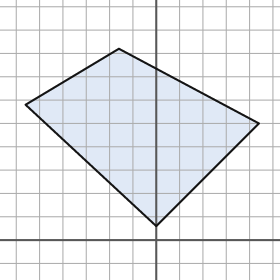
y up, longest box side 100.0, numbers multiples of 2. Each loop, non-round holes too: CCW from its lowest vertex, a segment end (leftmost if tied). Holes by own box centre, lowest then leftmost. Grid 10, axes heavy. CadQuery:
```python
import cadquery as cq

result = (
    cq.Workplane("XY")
    .moveTo(0.0, 6.0)
    .lineTo(44.0, 50.0)
    .lineTo(-16.0, 82.0)
    .lineTo(-56.0, 58.0)
    .close()
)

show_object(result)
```